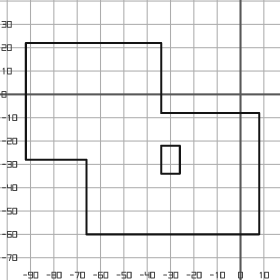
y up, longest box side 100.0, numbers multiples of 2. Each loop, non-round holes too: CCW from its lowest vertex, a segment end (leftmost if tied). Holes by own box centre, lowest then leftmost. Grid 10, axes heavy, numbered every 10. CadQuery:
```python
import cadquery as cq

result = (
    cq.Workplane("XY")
    .moveTo(-66.0, -60.0)
    .lineTo(8.0, -60.0)
    .lineTo(8.0, -8.0)
    .lineTo(-34.0, -8.0)
    .lineTo(-34.0, 22.0)
    .lineTo(-92.0, 22.0)
    .lineTo(-92.0, -28.0)
    .lineTo(-66.0, -28.0)
    .close()
    .moveTo(-34.0, -34.0)
    .lineTo(-26.0, -34.0)
    .lineTo(-26.0, -22.0)
    .lineTo(-34.0, -22.0)
    .close()
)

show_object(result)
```